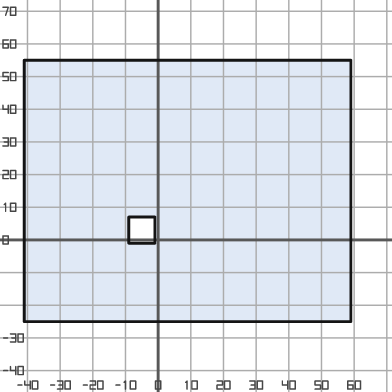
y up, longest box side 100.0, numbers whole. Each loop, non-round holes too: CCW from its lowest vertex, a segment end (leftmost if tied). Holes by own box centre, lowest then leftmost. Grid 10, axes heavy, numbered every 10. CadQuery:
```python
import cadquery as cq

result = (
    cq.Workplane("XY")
    .moveTo(-41.0, -25.0)
    .lineTo(59.0, -25.0)
    .lineTo(59.0, 55.0)
    .lineTo(-41.0, 55.0)
    .close()
    .moveTo(-9.0, -1.0)
    .lineTo(-1.0, -1.0)
    .lineTo(-1.0, 7.0)
    .lineTo(-9.0, 7.0)
    .close()
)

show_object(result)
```